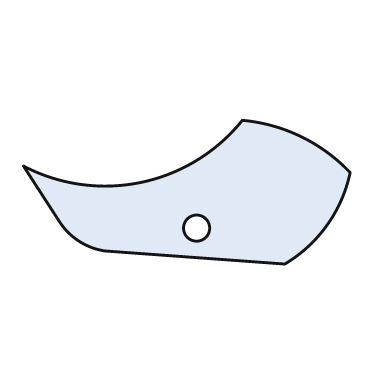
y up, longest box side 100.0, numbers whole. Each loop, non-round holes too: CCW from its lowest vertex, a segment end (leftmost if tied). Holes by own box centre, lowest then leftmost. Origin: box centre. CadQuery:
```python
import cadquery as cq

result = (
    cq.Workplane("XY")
    .moveTo(30.0, -22.0)
    .threePointArc((43.0, -10.0), (50.0, 6.0))
    .threePointArc((35.0, 17.0), (17.0, 22.0))
    .threePointArc((-14.0, 3.0), (-50.0, 8.0))
    .lineTo(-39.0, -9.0)
    .threePointArc((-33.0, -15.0), (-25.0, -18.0))
    .close()
    .moveTo(3.0, -11.0)
    .circle(4.0)
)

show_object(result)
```